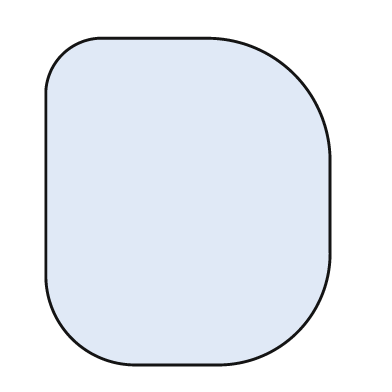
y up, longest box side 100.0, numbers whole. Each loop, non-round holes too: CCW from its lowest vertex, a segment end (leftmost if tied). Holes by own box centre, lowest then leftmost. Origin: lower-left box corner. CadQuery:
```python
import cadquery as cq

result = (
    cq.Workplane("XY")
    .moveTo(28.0, 0.0)
    .lineTo(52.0, 0.0)
    .threePointArc((77.0, 10.0), (87.0, 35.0))
    .lineTo(87.0, 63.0)
    .threePointArc((76.0, 89.0), (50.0, 100.0))
    .lineTo(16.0, 100.0)
    .threePointArc((5.0, 95.0), (0.0, 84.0))
    .lineTo(0.0, 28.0)
    .threePointArc((8.0, 8.0), (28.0, 0.0))
    .close()
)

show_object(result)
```